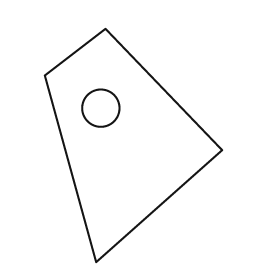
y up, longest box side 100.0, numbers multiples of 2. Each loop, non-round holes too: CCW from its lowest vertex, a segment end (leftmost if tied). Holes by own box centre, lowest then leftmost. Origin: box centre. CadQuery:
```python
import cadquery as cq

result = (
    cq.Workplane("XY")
    .moveTo(-16.0, -50.0)
    .lineTo(38.0, -2.0)
    .lineTo(-12.0, 50.0)
    .lineTo(-38.0, 30.0)
    .close()
    .moveTo(-14.0, 16.0)
    .circle(8.0)
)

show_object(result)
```